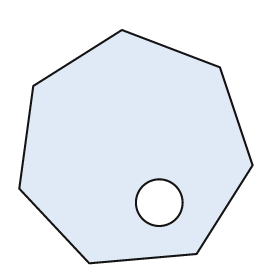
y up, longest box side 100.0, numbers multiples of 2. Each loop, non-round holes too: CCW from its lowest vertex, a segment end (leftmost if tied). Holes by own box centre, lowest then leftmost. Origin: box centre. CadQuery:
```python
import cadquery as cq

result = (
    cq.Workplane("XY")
    .moveTo(-20.0, -50.0)
    .lineTo(26.0, -46.0)
    .lineTo(50.0, -8.0)
    .lineTo(36.0, 34.0)
    .lineTo(-6.0, 50.0)
    .lineTo(-44.0, 26.0)
    .lineTo(-50.0, -18.0)
    .close()
    .moveTo(10.0, -24.0)
    .circle(10.0)
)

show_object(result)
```